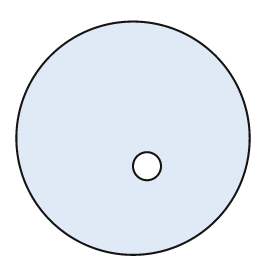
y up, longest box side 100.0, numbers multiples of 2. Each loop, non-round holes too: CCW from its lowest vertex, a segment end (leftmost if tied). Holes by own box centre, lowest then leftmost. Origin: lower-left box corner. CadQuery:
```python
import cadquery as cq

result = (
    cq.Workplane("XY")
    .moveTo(50.0, 50.0)
    .circle(50.0)
    .moveTo(56.0, 38.0)
    .circle(6.0)
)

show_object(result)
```